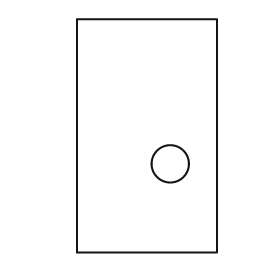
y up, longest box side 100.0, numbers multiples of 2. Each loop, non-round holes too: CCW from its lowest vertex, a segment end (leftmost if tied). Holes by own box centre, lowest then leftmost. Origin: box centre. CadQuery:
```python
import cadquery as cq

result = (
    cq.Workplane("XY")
    .moveTo(-30.0, -50.0)
    .lineTo(30.0, -50.0)
    .lineTo(30.0, 50.0)
    .lineTo(-30.0, 50.0)
    .close()
    .moveTo(10.0, -12.0)
    .circle(8.0)
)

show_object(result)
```